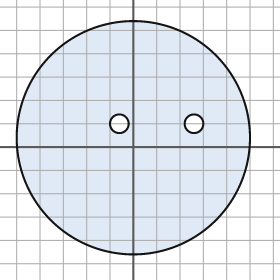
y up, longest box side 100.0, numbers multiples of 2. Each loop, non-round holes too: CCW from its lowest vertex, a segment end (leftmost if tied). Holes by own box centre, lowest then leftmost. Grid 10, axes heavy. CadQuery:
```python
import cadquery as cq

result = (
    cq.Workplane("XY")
    .moveTo(0.0, 4.0)
    .circle(50.0)
    .moveTo(-6.0, 10.0)
    .circle(4.0)
    .moveTo(26.0, 10.0)
    .circle(4.0)
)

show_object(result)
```